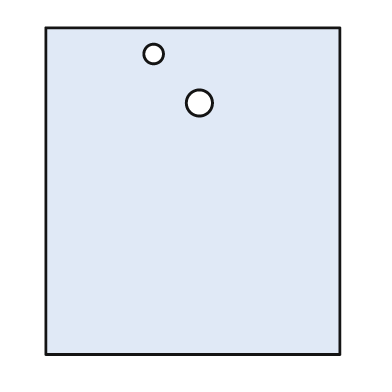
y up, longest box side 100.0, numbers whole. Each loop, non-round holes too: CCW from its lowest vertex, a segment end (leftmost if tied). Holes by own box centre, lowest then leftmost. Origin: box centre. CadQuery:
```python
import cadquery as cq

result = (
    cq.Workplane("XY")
    .moveTo(-45.0, -50.0)
    .lineTo(45.0, -50.0)
    .lineTo(45.0, 50.0)
    .lineTo(-45.0, 50.0)
    .close()
    .moveTo(2.0, 27.0)
    .circle(4.0)
    .moveTo(-12.0, 42.0)
    .circle(3.0)
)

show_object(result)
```